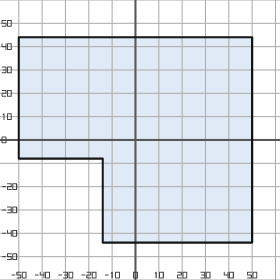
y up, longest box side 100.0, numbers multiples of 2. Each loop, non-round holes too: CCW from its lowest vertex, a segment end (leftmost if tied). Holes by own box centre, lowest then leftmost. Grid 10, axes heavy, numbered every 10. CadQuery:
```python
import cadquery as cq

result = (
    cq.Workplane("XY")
    .moveTo(-14.0, -44.0)
    .lineTo(50.0, -44.0)
    .lineTo(50.0, 44.0)
    .lineTo(-50.0, 44.0)
    .lineTo(-50.0, -8.0)
    .lineTo(-14.0, -8.0)
    .close()
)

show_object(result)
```